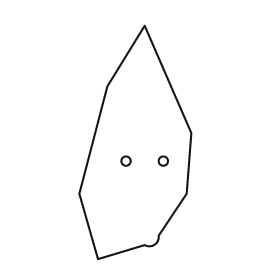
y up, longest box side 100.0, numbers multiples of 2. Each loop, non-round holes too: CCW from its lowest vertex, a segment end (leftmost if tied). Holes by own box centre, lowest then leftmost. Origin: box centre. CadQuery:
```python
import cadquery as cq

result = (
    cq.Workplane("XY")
    .moveTo(-16.0, -50.0)
    .lineTo(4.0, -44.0)
    .threePointArc((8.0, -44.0), (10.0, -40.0))
    .lineTo(22.0, -22.0)
    .lineTo(24.0, 4.0)
    .lineTo(4.0, 50.0)
    .lineTo(-12.0, 24.0)
    .lineTo(-24.0, -22.0)
    .close()
    .moveTo(-4.0, -8.0)
    .circle(2.0)
    .moveTo(12.0, -8.0)
    .circle(2.0)
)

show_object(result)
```